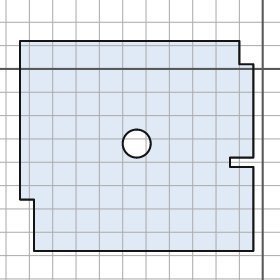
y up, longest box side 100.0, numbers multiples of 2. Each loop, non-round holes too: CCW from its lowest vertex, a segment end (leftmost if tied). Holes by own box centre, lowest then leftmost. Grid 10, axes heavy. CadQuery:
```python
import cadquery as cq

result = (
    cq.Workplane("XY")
    .moveTo(-98.0, -78.0)
    .lineTo(-4.0, -78.0)
    .lineTo(-4.0, -42.0)
    .lineTo(-14.0, -42.0)
    .lineTo(-14.0, -38.0)
    .lineTo(-4.0, -38.0)
    .lineTo(-4.0, 2.0)
    .lineTo(-10.0, 2.0)
    .lineTo(-10.0, 12.0)
    .lineTo(-104.0, 12.0)
    .lineTo(-104.0, -56.0)
    .lineTo(-98.0, -56.0)
    .close()
    .moveTo(-54.0, -32.0)
    .circle(6.0)
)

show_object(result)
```